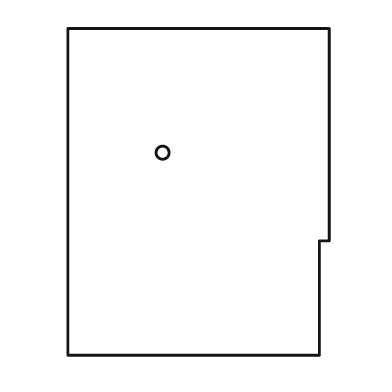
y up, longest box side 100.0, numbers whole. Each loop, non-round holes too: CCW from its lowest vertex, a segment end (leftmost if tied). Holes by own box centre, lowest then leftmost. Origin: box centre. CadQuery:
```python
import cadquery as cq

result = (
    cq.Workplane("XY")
    .moveTo(-40.0, -50.0)
    .lineTo(37.0, -50.0)
    .lineTo(37.0, -15.0)
    .lineTo(40.0, -15.0)
    .lineTo(40.0, 50.0)
    .lineTo(-40.0, 50.0)
    .close()
    .moveTo(-11.0, 12.0)
    .circle(2.0)
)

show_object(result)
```